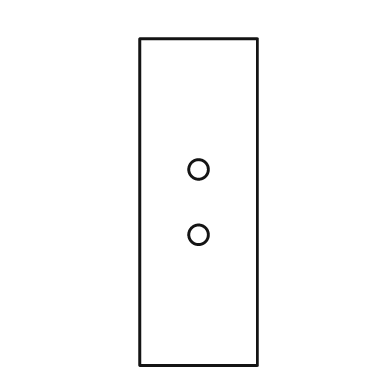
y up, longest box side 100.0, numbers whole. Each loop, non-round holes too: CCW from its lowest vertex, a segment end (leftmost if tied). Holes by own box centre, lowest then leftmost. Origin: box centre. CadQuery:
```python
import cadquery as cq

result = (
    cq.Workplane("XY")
    .moveTo(-18.0, -50.0)
    .lineTo(18.0, -50.0)
    .lineTo(18.0, 50.0)
    .lineTo(-18.0, 50.0)
    .close()
    .moveTo(0.0, -10.0)
    .circle(3.0)
    .moveTo(0.0, 10.0)
    .circle(3.0)
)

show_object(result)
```